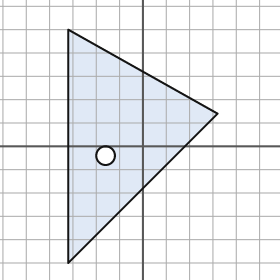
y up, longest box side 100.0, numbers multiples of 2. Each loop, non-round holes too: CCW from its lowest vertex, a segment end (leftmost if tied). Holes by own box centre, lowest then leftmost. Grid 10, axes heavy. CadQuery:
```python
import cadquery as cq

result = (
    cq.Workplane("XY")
    .moveTo(-32.0, -50.0)
    .lineTo(32.0, 14.0)
    .lineTo(-32.0, 50.0)
    .close()
    .moveTo(-16.0, -4.0)
    .circle(4.0)
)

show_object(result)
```